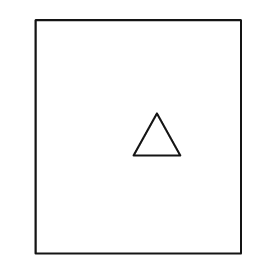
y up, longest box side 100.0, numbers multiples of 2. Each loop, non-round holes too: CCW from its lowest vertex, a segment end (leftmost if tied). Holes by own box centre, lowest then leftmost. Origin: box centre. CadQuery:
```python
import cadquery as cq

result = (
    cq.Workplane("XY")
    .moveTo(-44.0, -50.0)
    .lineTo(44.0, -50.0)
    .lineTo(44.0, 50.0)
    .lineTo(-44.0, 50.0)
    .close()
    .moveTo(-2.0, -8.0)
    .lineTo(18.0, -8.0)
    .lineTo(8.0, 10.0)
    .close()
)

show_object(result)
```